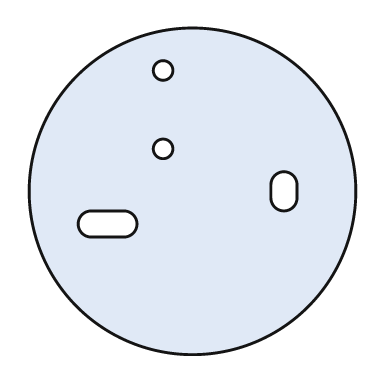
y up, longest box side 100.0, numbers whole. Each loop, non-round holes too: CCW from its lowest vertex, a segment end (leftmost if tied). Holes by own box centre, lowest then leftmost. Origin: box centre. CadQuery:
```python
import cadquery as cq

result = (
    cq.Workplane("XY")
    .moveTo(0.0, 0.0)
    .circle(50.0)
    .moveTo(-31.0, -14.0)
    .lineTo(-21.0, -14.0)
    .threePointArc((-17.0, -10.0), (-21.0, -6.0))
    .lineTo(-31.0, -6.0)
    .threePointArc((-35.0, -10.0), (-31.0, -14.0))
    .close()
    .moveTo(24.0, -2.0)
    .threePointArc((28.0, -6.0), (32.0, -2.0))
    .lineTo(32.0, 2.0)
    .threePointArc((28.0, 6.0), (24.0, 2.0))
    .close()
    .moveTo(-9.0, 13.0)
    .circle(3.0)
    .moveTo(-9.0, 37.0)
    .circle(3.0)
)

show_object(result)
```